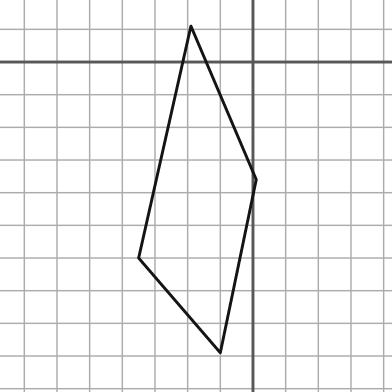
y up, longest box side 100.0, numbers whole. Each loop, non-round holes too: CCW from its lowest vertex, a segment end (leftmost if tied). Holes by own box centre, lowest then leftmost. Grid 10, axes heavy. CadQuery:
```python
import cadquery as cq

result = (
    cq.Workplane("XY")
    .moveTo(-10.0, -89.0)
    .lineTo(1.0, -36.0)
    .lineTo(-19.0, 11.0)
    .lineTo(-35.0, -60.0)
    .close()
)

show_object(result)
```